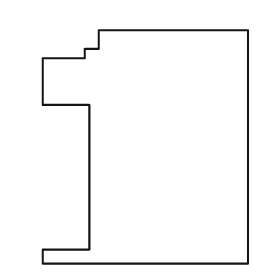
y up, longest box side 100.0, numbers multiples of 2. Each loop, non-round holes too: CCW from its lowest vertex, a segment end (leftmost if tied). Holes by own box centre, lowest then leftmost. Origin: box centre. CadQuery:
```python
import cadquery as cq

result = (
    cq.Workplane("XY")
    .moveTo(-44.0, -50.0)
    .lineTo(44.0, -50.0)
    .lineTo(44.0, 50.0)
    .lineTo(-20.0, 50.0)
    .lineTo(-20.0, 42.0)
    .lineTo(-26.0, 42.0)
    .lineTo(-26.0, 38.0)
    .lineTo(-44.0, 38.0)
    .lineTo(-44.0, 18.0)
    .lineTo(-24.0, 18.0)
    .lineTo(-24.0, -44.0)
    .lineTo(-44.0, -44.0)
    .close()
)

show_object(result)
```